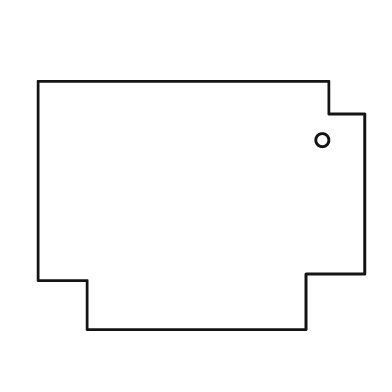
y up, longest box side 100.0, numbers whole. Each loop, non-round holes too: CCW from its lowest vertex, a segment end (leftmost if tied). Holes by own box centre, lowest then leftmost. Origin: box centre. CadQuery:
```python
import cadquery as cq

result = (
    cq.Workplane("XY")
    .moveTo(-35.0, -38.0)
    .lineTo(32.0, -38.0)
    .lineTo(32.0, -21.0)
    .lineTo(50.0, -21.0)
    .lineTo(50.0, 28.0)
    .lineTo(39.0, 28.0)
    .lineTo(39.0, 38.0)
    .lineTo(-50.0, 38.0)
    .lineTo(-50.0, -23.0)
    .lineTo(-35.0, -23.0)
    .close()
    .moveTo(37.0, 20.0)
    .circle(2.0)
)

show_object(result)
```